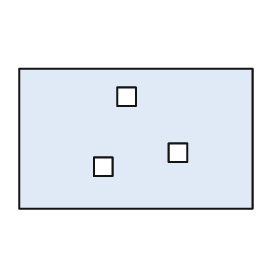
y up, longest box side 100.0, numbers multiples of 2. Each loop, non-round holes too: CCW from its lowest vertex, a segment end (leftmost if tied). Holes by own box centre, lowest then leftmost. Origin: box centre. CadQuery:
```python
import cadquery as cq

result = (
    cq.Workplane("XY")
    .moveTo(-50.0, -30.0)
    .lineTo(50.0, -30.0)
    .lineTo(50.0, 30.0)
    .lineTo(-50.0, 30.0)
    .close()
    .moveTo(-18.0, -16.0)
    .lineTo(-10.0, -16.0)
    .lineTo(-10.0, -8.0)
    .lineTo(-18.0, -8.0)
    .close()
    .moveTo(14.0, -10.0)
    .lineTo(22.0, -10.0)
    .lineTo(22.0, -2.0)
    .lineTo(14.0, -2.0)
    .close()
    .moveTo(-8.0, 14.0)
    .lineTo(0.0, 14.0)
    .lineTo(0.0, 22.0)
    .lineTo(-8.0, 22.0)
    .close()
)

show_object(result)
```